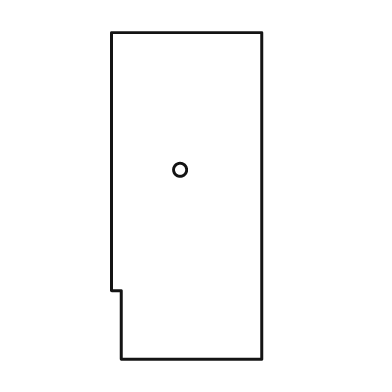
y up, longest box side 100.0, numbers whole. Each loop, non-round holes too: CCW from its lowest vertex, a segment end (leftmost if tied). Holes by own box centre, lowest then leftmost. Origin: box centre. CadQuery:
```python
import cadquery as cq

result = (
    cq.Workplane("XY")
    .moveTo(-20.0, -50.0)
    .lineTo(23.0, -50.0)
    .lineTo(23.0, 50.0)
    .lineTo(-23.0, 50.0)
    .lineTo(-23.0, -29.0)
    .lineTo(-20.0, -29.0)
    .close()
    .moveTo(-2.0, 8.0)
    .circle(2.0)
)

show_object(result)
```